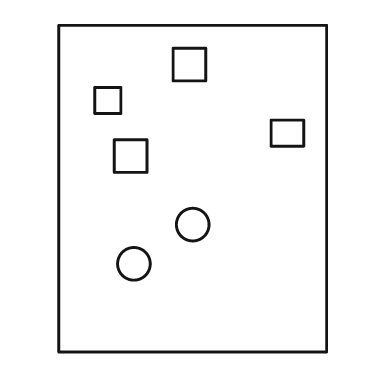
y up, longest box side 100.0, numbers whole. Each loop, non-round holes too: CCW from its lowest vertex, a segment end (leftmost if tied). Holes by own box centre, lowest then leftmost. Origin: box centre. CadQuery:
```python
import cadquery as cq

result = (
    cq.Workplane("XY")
    .moveTo(-41.0, -50.0)
    .lineTo(41.0, -50.0)
    .lineTo(41.0, 50.0)
    .lineTo(-41.0, 50.0)
    .close()
    .moveTo(-18.0, -23.0)
    .circle(5.0)
    .moveTo(0.0, -11.0)
    .circle(5.0)
    .moveTo(-24.0, 5.0)
    .lineTo(-14.0, 5.0)
    .lineTo(-14.0, 15.0)
    .lineTo(-24.0, 15.0)
    .close()
    .moveTo(24.0, 13.0)
    .lineTo(34.0, 13.0)
    .lineTo(34.0, 21.0)
    .lineTo(24.0, 21.0)
    .close()
    .moveTo(-30.0, 23.0)
    .lineTo(-22.0, 23.0)
    .lineTo(-22.0, 31.0)
    .lineTo(-30.0, 31.0)
    .close()
    .moveTo(-6.0, 33.0)
    .lineTo(4.0, 33.0)
    .lineTo(4.0, 43.0)
    .lineTo(-6.0, 43.0)
    .close()
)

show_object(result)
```